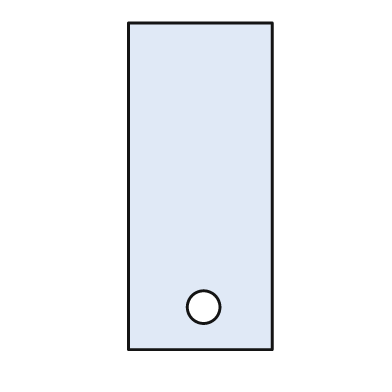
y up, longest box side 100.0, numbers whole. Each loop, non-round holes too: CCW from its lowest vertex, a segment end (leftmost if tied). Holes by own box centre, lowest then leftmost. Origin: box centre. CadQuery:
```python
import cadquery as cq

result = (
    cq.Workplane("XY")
    .moveTo(-22.0, -50.0)
    .lineTo(22.0, -50.0)
    .lineTo(22.0, 50.0)
    .lineTo(-22.0, 50.0)
    .close()
    .moveTo(1.0, -37.0)
    .circle(5.0)
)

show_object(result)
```